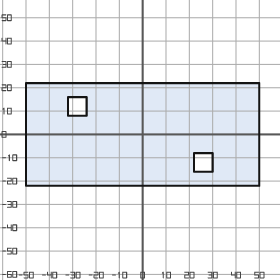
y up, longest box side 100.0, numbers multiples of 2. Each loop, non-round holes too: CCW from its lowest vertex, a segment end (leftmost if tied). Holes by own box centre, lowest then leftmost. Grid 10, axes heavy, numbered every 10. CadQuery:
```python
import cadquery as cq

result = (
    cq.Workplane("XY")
    .moveTo(-50.0, -22.0)
    .lineTo(50.0, -22.0)
    .lineTo(50.0, 22.0)
    .lineTo(-50.0, 22.0)
    .close()
    .moveTo(22.0, -16.0)
    .lineTo(30.0, -16.0)
    .lineTo(30.0, -8.0)
    .lineTo(22.0, -8.0)
    .close()
    .moveTo(-32.0, 8.0)
    .lineTo(-24.0, 8.0)
    .lineTo(-24.0, 16.0)
    .lineTo(-32.0, 16.0)
    .close()
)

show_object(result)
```